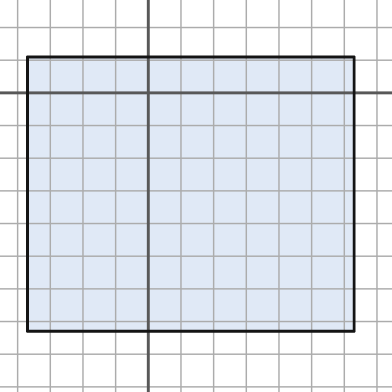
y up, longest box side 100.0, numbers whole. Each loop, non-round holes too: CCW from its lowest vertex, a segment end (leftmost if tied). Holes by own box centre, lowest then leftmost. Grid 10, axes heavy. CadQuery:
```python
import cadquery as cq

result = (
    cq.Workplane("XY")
    .moveTo(-37.0, -73.0)
    .lineTo(63.0, -73.0)
    .lineTo(63.0, 11.0)
    .lineTo(-37.0, 11.0)
    .close()
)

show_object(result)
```